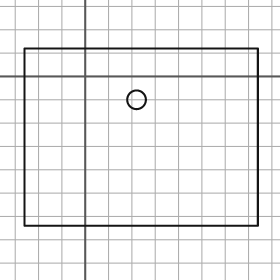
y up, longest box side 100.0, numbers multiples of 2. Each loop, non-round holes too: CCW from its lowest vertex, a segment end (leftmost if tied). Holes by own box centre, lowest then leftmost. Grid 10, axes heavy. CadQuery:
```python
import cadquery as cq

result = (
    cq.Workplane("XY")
    .moveTo(-26.0, -64.0)
    .lineTo(74.0, -64.0)
    .lineTo(74.0, 12.0)
    .lineTo(-26.0, 12.0)
    .close()
    .moveTo(22.0, -10.0)
    .circle(4.0)
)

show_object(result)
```